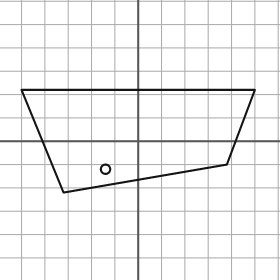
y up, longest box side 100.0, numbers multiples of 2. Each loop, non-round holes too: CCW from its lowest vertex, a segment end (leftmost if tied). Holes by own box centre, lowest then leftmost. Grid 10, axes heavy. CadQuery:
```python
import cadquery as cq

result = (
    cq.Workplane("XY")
    .moveTo(-32.0, -22.0)
    .lineTo(38.0, -10.0)
    .lineTo(50.0, 22.0)
    .lineTo(-50.0, 22.0)
    .close()
    .moveTo(-14.0, -12.0)
    .circle(2.0)
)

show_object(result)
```